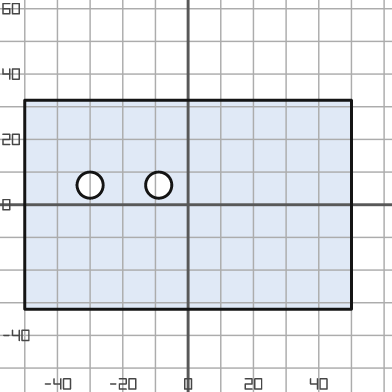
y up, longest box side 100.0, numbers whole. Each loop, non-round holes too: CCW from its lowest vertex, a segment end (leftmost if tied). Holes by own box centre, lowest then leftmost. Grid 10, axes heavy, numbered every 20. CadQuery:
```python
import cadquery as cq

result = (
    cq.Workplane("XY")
    .moveTo(-50.0, -32.0)
    .lineTo(50.0, -32.0)
    .lineTo(50.0, 32.0)
    .lineTo(-50.0, 32.0)
    .close()
    .moveTo(-30.0, 6.0)
    .circle(4.0)
    .moveTo(-9.0, 6.0)
    .circle(4.0)
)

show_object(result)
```